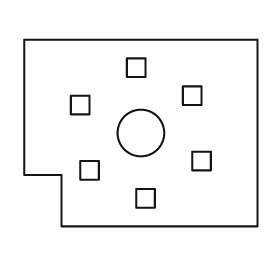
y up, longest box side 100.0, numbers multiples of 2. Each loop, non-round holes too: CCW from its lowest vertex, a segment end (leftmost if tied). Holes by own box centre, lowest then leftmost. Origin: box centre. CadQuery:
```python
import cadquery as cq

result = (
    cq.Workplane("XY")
    .moveTo(-34.0, -40.0)
    .lineTo(50.0, -40.0)
    .lineTo(50.0, 40.0)
    .lineTo(-50.0, 40.0)
    .lineTo(-50.0, -18.0)
    .lineTo(-34.0, -18.0)
    .close()
    .moveTo(-2.0, -32.0)
    .lineTo(6.0, -32.0)
    .lineTo(6.0, -24.0)
    .lineTo(-2.0, -24.0)
    .close()
    .moveTo(-26.0, -20.0)
    .lineTo(-18.0, -20.0)
    .lineTo(-18.0, -12.0)
    .lineTo(-26.0, -12.0)
    .close()
    .moveTo(22.0, -16.0)
    .lineTo(30.0, -16.0)
    .lineTo(30.0, -8.0)
    .lineTo(22.0, -8.0)
    .close()
    .moveTo(0.0, 0.0)
    .circle(10.0)
    .moveTo(-30.0, 8.0)
    .lineTo(-22.0, 8.0)
    .lineTo(-22.0, 16.0)
    .lineTo(-30.0, 16.0)
    .close()
    .moveTo(18.0, 12.0)
    .lineTo(26.0, 12.0)
    .lineTo(26.0, 20.0)
    .lineTo(18.0, 20.0)
    .close()
    .moveTo(-6.0, 24.0)
    .lineTo(2.0, 24.0)
    .lineTo(2.0, 32.0)
    .lineTo(-6.0, 32.0)
    .close()
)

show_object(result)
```